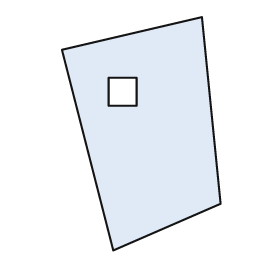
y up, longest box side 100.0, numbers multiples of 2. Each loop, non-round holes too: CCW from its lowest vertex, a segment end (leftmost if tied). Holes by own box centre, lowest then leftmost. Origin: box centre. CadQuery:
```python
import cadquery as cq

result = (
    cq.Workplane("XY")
    .moveTo(-12.0, -50.0)
    .lineTo(34.0, -30.0)
    .lineTo(26.0, 50.0)
    .lineTo(-34.0, 36.0)
    .close()
    .moveTo(-14.0, 12.0)
    .lineTo(-2.0, 12.0)
    .lineTo(-2.0, 24.0)
    .lineTo(-14.0, 24.0)
    .close()
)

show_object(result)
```